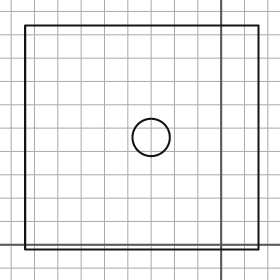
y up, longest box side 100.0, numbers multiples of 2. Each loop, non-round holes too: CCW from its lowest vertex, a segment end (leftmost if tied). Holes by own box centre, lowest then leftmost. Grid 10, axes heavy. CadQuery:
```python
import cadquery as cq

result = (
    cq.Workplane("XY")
    .moveTo(-84.0, -2.0)
    .lineTo(16.0, -2.0)
    .lineTo(16.0, 94.0)
    .lineTo(-84.0, 94.0)
    .close()
    .moveTo(-30.0, 46.0)
    .circle(8.0)
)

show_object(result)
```